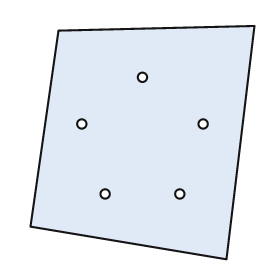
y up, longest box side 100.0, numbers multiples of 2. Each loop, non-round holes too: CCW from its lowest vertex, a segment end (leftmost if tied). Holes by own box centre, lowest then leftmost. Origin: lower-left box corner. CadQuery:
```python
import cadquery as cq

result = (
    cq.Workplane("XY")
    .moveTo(84.0, 0.0)
    .lineTo(96.0, 100.0)
    .lineTo(12.0, 98.0)
    .lineTo(0.0, 14.0)
    .close()
    .moveTo(32.0, 28.0)
    .circle(2.0)
    .moveTo(64.0, 28.0)
    .circle(2.0)
    .moveTo(22.0, 58.0)
    .circle(2.0)
    .moveTo(74.0, 58.0)
    .circle(2.0)
    .moveTo(48.0, 78.0)
    .circle(2.0)
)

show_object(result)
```